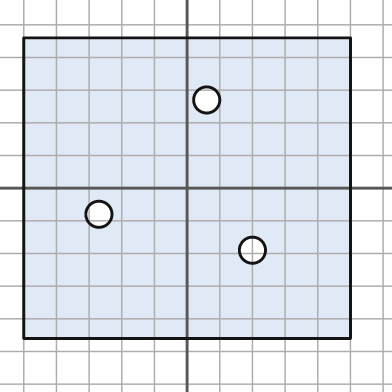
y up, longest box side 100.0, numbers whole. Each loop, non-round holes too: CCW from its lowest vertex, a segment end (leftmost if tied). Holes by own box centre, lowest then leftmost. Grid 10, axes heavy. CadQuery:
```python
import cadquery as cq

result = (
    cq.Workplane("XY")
    .moveTo(-50.0, -46.0)
    .lineTo(50.0, -46.0)
    .lineTo(50.0, 46.0)
    .lineTo(-50.0, 46.0)
    .close()
    .moveTo(20.0, -19.0)
    .circle(4.0)
    .moveTo(-27.0, -8.0)
    .circle(4.0)
    .moveTo(6.0, 27.0)
    .circle(4.0)
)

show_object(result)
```